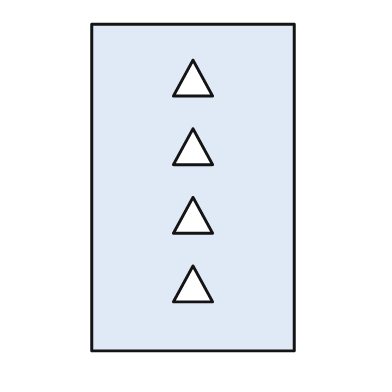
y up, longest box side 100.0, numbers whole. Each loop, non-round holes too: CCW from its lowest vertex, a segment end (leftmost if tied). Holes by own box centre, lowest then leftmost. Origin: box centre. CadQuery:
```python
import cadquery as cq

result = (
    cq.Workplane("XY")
    .moveTo(-31.0, -50.0)
    .lineTo(31.0, -50.0)
    .lineTo(31.0, 50.0)
    .lineTo(-31.0, 50.0)
    .close()
    .moveTo(-6.0, -35.0)
    .lineTo(6.0, -35.0)
    .lineTo(0.0, -24.0)
    .close()
    .moveTo(-6.0, -14.0)
    .lineTo(6.0, -14.0)
    .lineTo(0.0, -3.0)
    .close()
    .moveTo(-6.0, 7.0)
    .lineTo(6.0, 7.0)
    .lineTo(0.0, 18.0)
    .close()
    .moveTo(-6.0, 28.0)
    .lineTo(6.0, 28.0)
    .lineTo(0.0, 39.0)
    .close()
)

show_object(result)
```